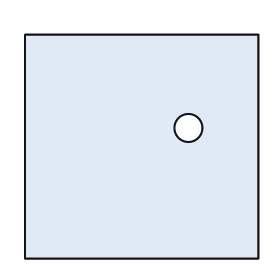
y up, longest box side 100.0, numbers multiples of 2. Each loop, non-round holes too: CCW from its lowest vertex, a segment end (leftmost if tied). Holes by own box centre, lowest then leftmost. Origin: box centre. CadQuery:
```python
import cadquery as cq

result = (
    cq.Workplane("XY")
    .moveTo(-50.0, -48.0)
    .lineTo(50.0, -48.0)
    .lineTo(50.0, 48.0)
    .lineTo(-50.0, 48.0)
    .close()
    .moveTo(20.0, 8.0)
    .circle(6.0)
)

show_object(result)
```